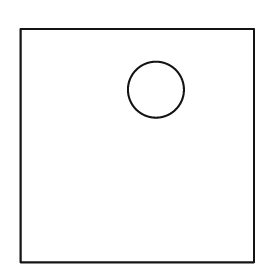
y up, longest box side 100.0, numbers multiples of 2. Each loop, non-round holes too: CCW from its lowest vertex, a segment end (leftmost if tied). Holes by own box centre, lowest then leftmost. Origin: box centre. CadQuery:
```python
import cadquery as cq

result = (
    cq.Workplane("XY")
    .moveTo(-50.0, -50.0)
    .lineTo(50.0, -50.0)
    .lineTo(50.0, 50.0)
    .lineTo(-50.0, 50.0)
    .close()
    .moveTo(8.0, 24.0)
    .circle(12.0)
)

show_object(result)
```